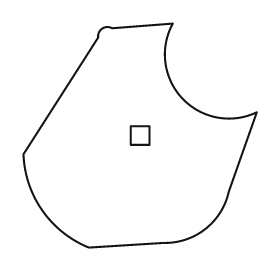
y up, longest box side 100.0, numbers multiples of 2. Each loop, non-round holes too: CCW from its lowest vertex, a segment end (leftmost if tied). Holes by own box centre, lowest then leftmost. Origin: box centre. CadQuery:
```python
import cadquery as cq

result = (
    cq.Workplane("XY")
    .moveTo(-22.0, -48.0)
    .lineTo(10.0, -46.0)
    .threePointArc((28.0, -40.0), (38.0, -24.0))
    .lineTo(50.0, 10.0)
    .threePointArc((18.0, 16.0), (14.0, 48.0))
    .lineTo(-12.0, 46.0)
    .threePointArc((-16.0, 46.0), (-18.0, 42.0))
    .lineTo(-50.0, -8.0)
    .threePointArc((-42.0, -32.0), (-22.0, -48.0))
    .close()
    .moveTo(-4.0, -4.0)
    .lineTo(4.0, -4.0)
    .lineTo(4.0, 4.0)
    .lineTo(-4.0, 4.0)
    .close()
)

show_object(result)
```